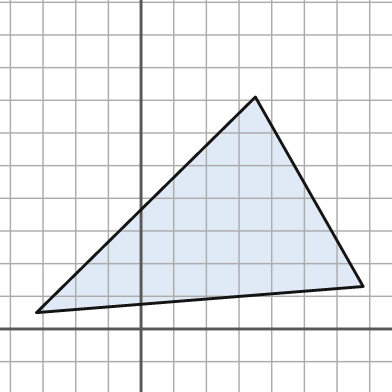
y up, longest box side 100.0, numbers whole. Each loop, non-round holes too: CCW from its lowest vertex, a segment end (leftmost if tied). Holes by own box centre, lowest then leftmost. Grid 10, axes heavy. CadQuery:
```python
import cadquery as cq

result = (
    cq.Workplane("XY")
    .moveTo(-32.0, 5.0)
    .lineTo(68.0, 13.0)
    .lineTo(35.0, 71.0)
    .close()
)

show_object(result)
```